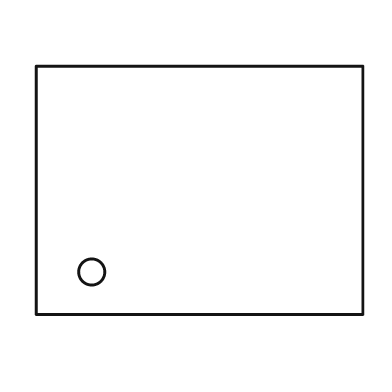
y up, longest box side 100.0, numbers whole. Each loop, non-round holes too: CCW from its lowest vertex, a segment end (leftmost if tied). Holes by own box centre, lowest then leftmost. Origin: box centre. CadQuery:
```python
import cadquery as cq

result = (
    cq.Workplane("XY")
    .moveTo(-50.0, -38.0)
    .lineTo(50.0, -38.0)
    .lineTo(50.0, 38.0)
    .lineTo(-50.0, 38.0)
    .close()
    .moveTo(-33.0, -25.0)
    .circle(4.0)
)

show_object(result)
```